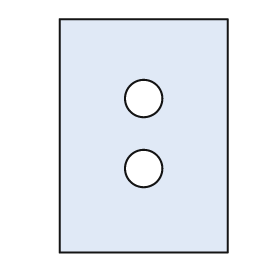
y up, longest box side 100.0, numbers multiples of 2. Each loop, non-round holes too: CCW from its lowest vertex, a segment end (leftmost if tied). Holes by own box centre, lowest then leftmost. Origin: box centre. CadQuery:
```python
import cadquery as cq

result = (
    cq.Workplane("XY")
    .moveTo(-36.0, -50.0)
    .lineTo(36.0, -50.0)
    .lineTo(36.0, 50.0)
    .lineTo(-36.0, 50.0)
    .close()
    .moveTo(0.0, -14.0)
    .circle(8.0)
    .moveTo(0.0, 16.0)
    .circle(8.0)
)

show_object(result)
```